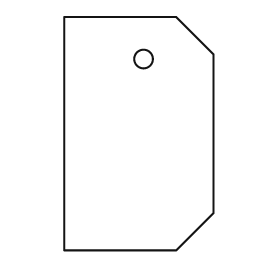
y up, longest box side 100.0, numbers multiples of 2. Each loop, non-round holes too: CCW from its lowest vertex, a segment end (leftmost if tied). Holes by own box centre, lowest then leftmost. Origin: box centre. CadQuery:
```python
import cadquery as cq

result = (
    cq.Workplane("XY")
    .moveTo(-32.0, -50.0)
    .lineTo(16.0, -50.0)
    .lineTo(32.0, -34.0)
    .lineTo(32.0, 34.0)
    .lineTo(16.0, 50.0)
    .lineTo(-32.0, 50.0)
    .close()
    .moveTo(2.0, 32.0)
    .circle(4.0)
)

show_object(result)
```